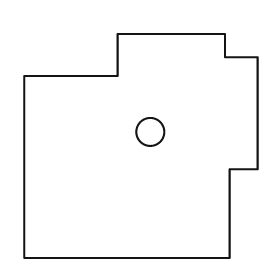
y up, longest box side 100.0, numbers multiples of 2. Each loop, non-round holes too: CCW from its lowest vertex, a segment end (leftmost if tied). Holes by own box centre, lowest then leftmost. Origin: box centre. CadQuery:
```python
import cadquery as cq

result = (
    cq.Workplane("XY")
    .moveTo(-50.0, -48.0)
    .lineTo(38.0, -48.0)
    .lineTo(38.0, -10.0)
    .lineTo(50.0, -10.0)
    .lineTo(50.0, 38.0)
    .lineTo(36.0, 38.0)
    .lineTo(36.0, 48.0)
    .lineTo(-10.0, 48.0)
    .lineTo(-10.0, 30.0)
    .lineTo(-50.0, 30.0)
    .close()
    .moveTo(4.0, 6.0)
    .circle(6.0)
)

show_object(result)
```